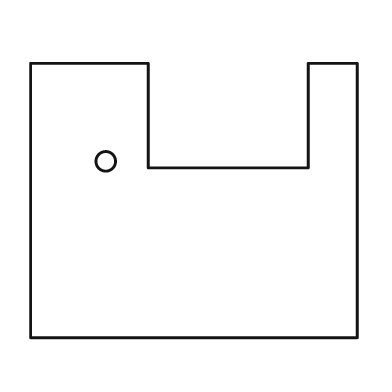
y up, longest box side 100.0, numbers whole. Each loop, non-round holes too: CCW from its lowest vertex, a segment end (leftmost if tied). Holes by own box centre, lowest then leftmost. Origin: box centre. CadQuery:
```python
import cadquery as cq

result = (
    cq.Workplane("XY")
    .moveTo(-50.0, -42.0)
    .lineTo(50.0, -42.0)
    .lineTo(50.0, 42.0)
    .lineTo(35.0, 42.0)
    .lineTo(35.0, 10.0)
    .lineTo(-14.0, 10.0)
    .lineTo(-14.0, 42.0)
    .lineTo(-50.0, 42.0)
    .close()
    .moveTo(-27.0, 12.0)
    .circle(3.0)
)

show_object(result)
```